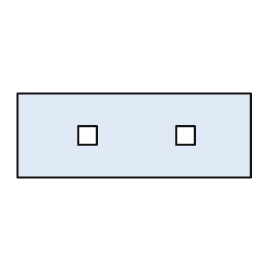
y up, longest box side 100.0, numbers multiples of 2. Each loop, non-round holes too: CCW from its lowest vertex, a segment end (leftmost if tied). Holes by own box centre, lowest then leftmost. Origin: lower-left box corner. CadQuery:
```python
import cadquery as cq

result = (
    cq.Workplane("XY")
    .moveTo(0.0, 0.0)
    .lineTo(100.0, 0.0)
    .lineTo(100.0, 36.0)
    .lineTo(0.0, 36.0)
    .close()
    .moveTo(26.0, 14.0)
    .lineTo(34.0, 14.0)
    .lineTo(34.0, 22.0)
    .lineTo(26.0, 22.0)
    .close()
    .moveTo(68.0, 14.0)
    .lineTo(76.0, 14.0)
    .lineTo(76.0, 22.0)
    .lineTo(68.0, 22.0)
    .close()
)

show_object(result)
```